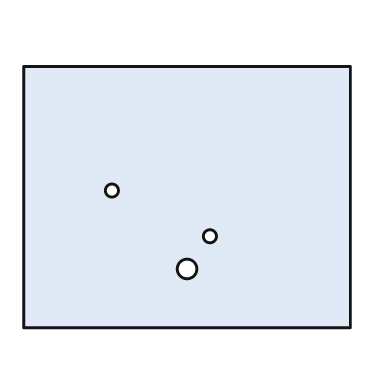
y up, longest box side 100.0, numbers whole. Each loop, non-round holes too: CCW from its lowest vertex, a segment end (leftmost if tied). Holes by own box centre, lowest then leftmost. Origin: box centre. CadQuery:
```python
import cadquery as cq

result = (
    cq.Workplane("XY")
    .moveTo(-50.0, -40.0)
    .lineTo(50.0, -40.0)
    .lineTo(50.0, 40.0)
    .lineTo(-50.0, 40.0)
    .close()
    .moveTo(0.0, -22.0)
    .circle(3.0)
    .moveTo(7.0, -12.0)
    .circle(2.0)
    .moveTo(-23.0, 2.0)
    .circle(2.0)
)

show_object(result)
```